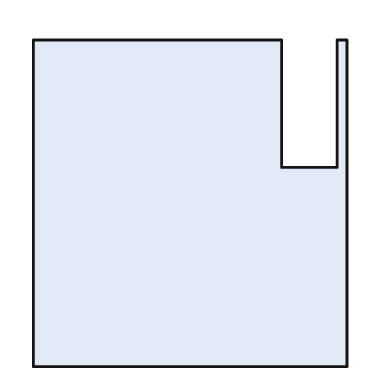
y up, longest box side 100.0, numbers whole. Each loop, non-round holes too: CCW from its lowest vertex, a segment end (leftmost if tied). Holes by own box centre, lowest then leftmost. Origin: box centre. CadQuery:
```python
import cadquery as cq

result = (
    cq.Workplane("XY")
    .moveTo(-48.0, -50.0)
    .lineTo(48.0, -50.0)
    .lineTo(48.0, 50.0)
    .lineTo(45.0, 50.0)
    .lineTo(45.0, 11.0)
    .lineTo(28.0, 11.0)
    .lineTo(28.0, 50.0)
    .lineTo(-48.0, 50.0)
    .close()
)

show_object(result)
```